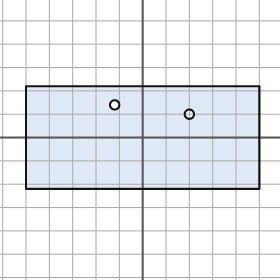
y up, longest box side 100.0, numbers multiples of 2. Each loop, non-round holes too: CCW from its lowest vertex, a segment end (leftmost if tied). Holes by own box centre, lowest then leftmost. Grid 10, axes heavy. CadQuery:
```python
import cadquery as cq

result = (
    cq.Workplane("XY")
    .moveTo(-50.0, -22.0)
    .lineTo(50.0, -22.0)
    .lineTo(50.0, 22.0)
    .lineTo(-50.0, 22.0)
    .close()
    .moveTo(20.0, 10.0)
    .circle(2.0)
    .moveTo(-12.0, 14.0)
    .circle(2.0)
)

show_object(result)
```